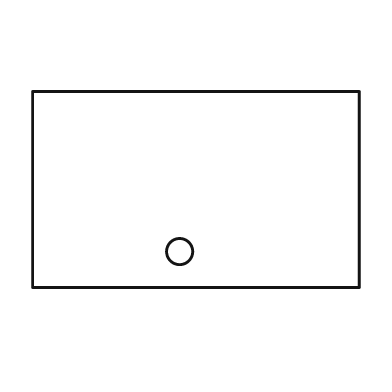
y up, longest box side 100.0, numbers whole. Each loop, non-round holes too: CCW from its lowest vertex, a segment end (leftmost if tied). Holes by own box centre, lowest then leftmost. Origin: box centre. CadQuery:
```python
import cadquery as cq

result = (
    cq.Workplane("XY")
    .moveTo(-50.0, -30.0)
    .lineTo(50.0, -30.0)
    .lineTo(50.0, 30.0)
    .lineTo(-50.0, 30.0)
    .close()
    .moveTo(-5.0, -19.0)
    .circle(4.0)
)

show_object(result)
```